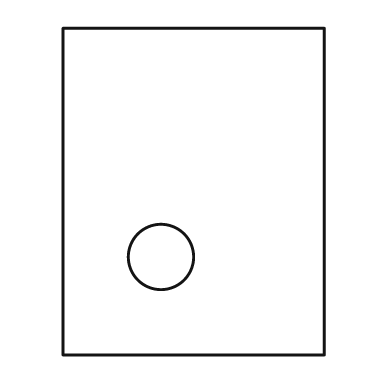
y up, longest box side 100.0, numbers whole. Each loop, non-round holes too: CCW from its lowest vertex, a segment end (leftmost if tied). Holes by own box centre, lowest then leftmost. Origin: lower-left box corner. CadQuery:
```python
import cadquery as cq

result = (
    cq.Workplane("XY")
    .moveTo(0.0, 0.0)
    .lineTo(80.0, 0.0)
    .lineTo(80.0, 100.0)
    .lineTo(0.0, 100.0)
    .close()
    .moveTo(30.0, 30.0)
    .circle(10.0)
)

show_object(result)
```